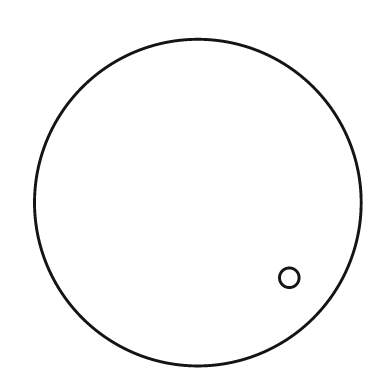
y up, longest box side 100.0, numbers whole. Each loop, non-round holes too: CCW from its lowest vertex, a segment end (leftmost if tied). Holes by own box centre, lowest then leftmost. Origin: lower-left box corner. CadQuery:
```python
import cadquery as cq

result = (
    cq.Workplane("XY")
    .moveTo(50.0, 50.0)
    .circle(50.0)
    .moveTo(78.0, 27.0)
    .circle(3.0)
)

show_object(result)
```